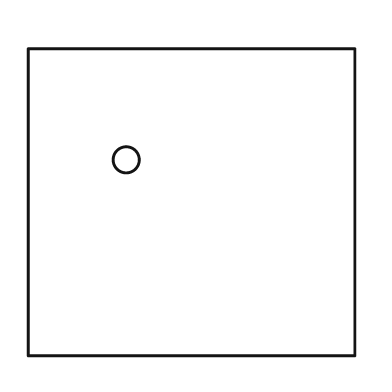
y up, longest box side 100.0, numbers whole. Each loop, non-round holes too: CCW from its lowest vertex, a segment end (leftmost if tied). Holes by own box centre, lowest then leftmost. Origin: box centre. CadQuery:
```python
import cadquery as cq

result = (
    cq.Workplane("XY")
    .moveTo(-50.0, -47.0)
    .lineTo(50.0, -47.0)
    .lineTo(50.0, 47.0)
    .lineTo(-50.0, 47.0)
    .close()
    .moveTo(-20.0, 13.0)
    .circle(4.0)
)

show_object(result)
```